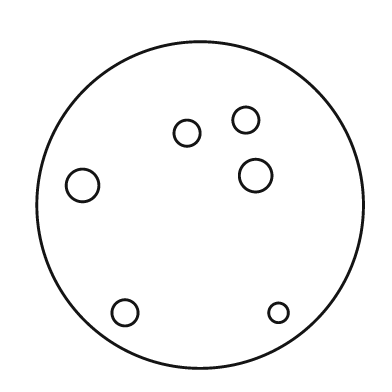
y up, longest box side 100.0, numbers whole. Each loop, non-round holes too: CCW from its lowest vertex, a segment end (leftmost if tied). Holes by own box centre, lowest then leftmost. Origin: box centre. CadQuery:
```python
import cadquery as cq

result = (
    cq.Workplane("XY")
    .moveTo(0.0, 0.0)
    .circle(50.0)
    .moveTo(-23.0, -33.0)
    .circle(4.0)
    .moveTo(24.0, -33.0)
    .circle(3.0)
    .moveTo(-36.0, 6.0)
    .circle(5.0)
    .moveTo(17.0, 9.0)
    .circle(5.0)
    .moveTo(-4.0, 22.0)
    .circle(4.0)
    .moveTo(14.0, 26.0)
    .circle(4.0)
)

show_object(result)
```